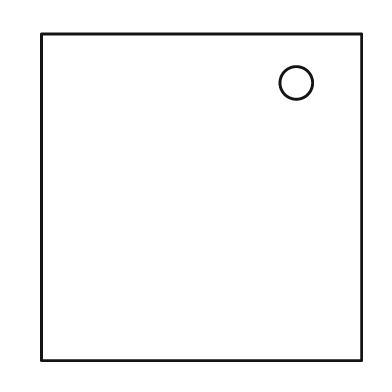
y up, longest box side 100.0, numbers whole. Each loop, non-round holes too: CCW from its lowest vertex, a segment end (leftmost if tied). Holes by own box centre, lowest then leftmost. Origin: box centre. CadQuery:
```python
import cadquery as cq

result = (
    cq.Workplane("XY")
    .moveTo(-49.0, -50.0)
    .lineTo(49.0, -50.0)
    .lineTo(49.0, 50.0)
    .lineTo(-49.0, 50.0)
    .close()
    .moveTo(29.0, 35.0)
    .circle(5.0)
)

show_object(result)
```